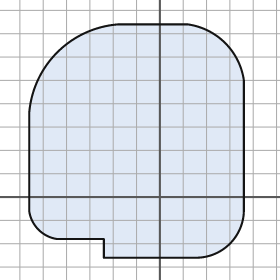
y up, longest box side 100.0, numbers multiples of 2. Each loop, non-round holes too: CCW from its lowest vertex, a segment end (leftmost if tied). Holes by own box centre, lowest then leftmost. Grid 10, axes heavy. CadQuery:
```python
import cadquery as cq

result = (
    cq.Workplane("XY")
    .moveTo(-24.0, -26.0)
    .lineTo(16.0, -26.0)
    .threePointArc((30.0, -20.0), (36.0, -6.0))
    .lineTo(36.0, 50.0)
    .threePointArc((28.0, 66.0), (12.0, 74.0))
    .lineTo(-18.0, 74.0)
    .threePointArc((-44.0, 62.0), (-56.0, 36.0))
    .lineTo(-56.0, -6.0)
    .threePointArc((-52.0, -14.0), (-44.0, -18.0))
    .lineTo(-24.0, -18.0)
    .close()
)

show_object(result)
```